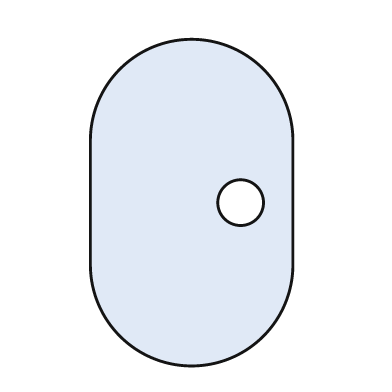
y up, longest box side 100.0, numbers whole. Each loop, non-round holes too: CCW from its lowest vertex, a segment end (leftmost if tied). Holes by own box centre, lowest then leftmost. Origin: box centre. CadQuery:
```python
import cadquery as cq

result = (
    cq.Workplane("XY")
    .moveTo(-31.0, -19.0)
    .threePointArc((0.0, -50.0), (31.0, -19.0))
    .lineTo(31.0, 19.0)
    .threePointArc((0.0, 50.0), (-31.0, 19.0))
    .close()
    .moveTo(15.0, 0.0)
    .circle(7.0)
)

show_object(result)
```